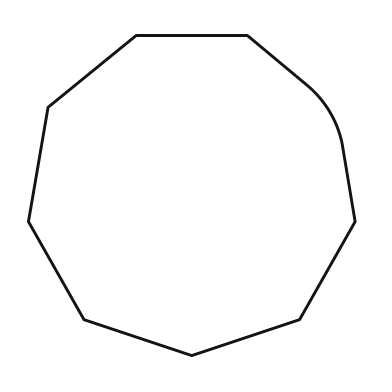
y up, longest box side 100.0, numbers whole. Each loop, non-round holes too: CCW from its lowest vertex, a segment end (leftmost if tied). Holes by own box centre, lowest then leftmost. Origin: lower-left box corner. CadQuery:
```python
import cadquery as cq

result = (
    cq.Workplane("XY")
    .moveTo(50.0, 0.0)
    .lineTo(83.0, 11.0)
    .lineTo(100.0, 41.0)
    .lineTo(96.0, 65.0)
    .threePointArc((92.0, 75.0), (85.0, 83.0))
    .lineTo(67.0, 98.0)
    .lineTo(33.0, 98.0)
    .lineTo(6.0, 76.0)
    .lineTo(0.0, 41.0)
    .lineTo(17.0, 11.0)
    .close()
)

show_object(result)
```